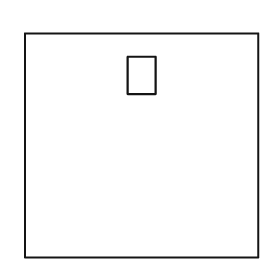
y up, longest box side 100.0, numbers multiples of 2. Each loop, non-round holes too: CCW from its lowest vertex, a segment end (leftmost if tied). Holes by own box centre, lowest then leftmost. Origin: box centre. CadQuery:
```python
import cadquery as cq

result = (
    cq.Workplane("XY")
    .moveTo(-50.0, -48.0)
    .lineTo(50.0, -48.0)
    .lineTo(50.0, 48.0)
    .lineTo(-50.0, 48.0)
    .close()
    .moveTo(-6.0, 22.0)
    .lineTo(6.0, 22.0)
    .lineTo(6.0, 38.0)
    .lineTo(-6.0, 38.0)
    .close()
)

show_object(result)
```